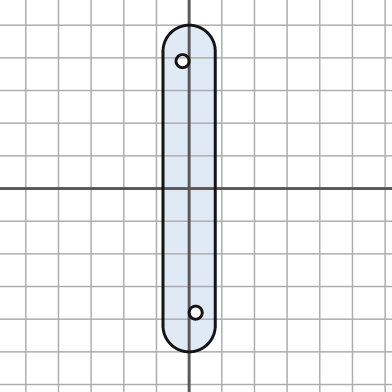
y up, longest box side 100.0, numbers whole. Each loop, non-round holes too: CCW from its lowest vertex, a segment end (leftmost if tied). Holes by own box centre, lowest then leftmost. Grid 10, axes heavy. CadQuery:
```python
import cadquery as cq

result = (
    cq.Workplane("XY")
    .moveTo(-8.0, -42.0)
    .threePointArc((0.0, -50.0), (8.0, -42.0))
    .lineTo(8.0, 42.0)
    .threePointArc((0.0, 50.0), (-8.0, 42.0))
    .close()
    .moveTo(2.0, -38.0)
    .circle(2.0)
    .moveTo(-2.0, 39.0)
    .circle(2.0)
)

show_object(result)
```